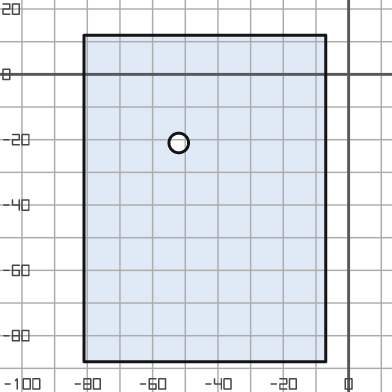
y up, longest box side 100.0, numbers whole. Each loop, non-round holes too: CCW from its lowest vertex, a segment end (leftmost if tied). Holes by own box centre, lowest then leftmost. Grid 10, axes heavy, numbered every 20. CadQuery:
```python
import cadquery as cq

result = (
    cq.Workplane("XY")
    .moveTo(-81.0, -88.0)
    .lineTo(-7.0, -88.0)
    .lineTo(-7.0, 12.0)
    .lineTo(-81.0, 12.0)
    .close()
    .moveTo(-52.0, -21.0)
    .circle(3.0)
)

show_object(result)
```